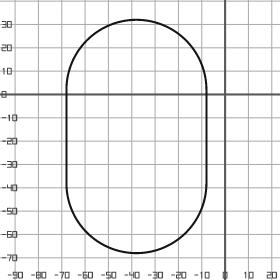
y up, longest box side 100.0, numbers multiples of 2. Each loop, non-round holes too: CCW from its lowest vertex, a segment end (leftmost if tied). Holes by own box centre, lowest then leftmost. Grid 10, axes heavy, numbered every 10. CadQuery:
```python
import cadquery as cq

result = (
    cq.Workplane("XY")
    .moveTo(-68.0, -38.0)
    .threePointArc((-38.0, -68.0), (-8.0, -38.0))
    .lineTo(-8.0, 2.0)
    .threePointArc((-38.0, 32.0), (-68.0, 2.0))
    .close()
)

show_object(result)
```